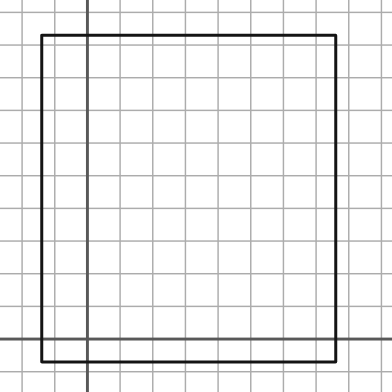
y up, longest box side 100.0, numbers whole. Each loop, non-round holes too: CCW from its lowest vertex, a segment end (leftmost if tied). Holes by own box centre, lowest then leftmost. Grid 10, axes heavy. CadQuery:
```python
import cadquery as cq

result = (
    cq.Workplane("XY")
    .moveTo(-14.0, -7.0)
    .lineTo(76.0, -7.0)
    .lineTo(76.0, 93.0)
    .lineTo(-14.0, 93.0)
    .close()
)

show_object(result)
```